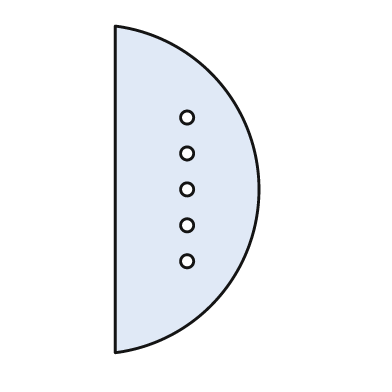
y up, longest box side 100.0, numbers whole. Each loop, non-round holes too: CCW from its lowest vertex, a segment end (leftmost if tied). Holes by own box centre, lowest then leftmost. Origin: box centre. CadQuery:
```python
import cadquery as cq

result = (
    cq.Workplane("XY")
    .moveTo(-22.0, -50.0)
    .threePointArc((22.0, 0.0), (-22.0, 50.0))
    .close()
    .moveTo(0.0, -22.0)
    .circle(2.0)
    .moveTo(0.0, -11.0)
    .circle(2.0)
    .moveTo(0.0, 0.0)
    .circle(2.0)
    .moveTo(0.0, 11.0)
    .circle(2.0)
    .moveTo(0.0, 22.0)
    .circle(2.0)
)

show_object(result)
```